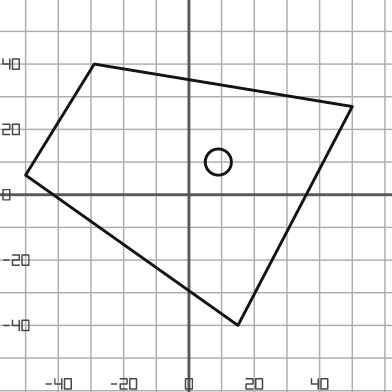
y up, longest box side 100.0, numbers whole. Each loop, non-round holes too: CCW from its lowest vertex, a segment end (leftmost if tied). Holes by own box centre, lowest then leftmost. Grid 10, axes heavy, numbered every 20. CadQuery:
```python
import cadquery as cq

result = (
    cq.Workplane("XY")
    .moveTo(15.0, -40.0)
    .lineTo(50.0, 27.0)
    .lineTo(-29.0, 40.0)
    .lineTo(-50.0, 6.0)
    .close()
    .moveTo(9.0, 10.0)
    .circle(4.0)
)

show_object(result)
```